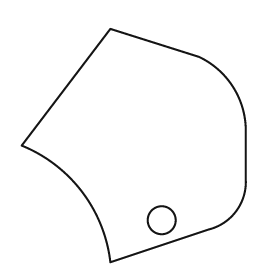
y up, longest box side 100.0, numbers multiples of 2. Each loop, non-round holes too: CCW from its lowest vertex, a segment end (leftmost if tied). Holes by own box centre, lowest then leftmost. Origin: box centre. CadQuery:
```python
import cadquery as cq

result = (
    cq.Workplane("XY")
    .moveTo(-10.0, -50.0)
    .lineTo(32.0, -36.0)
    .threePointArc((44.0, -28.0), (48.0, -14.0))
    .lineTo(48.0, 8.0)
    .threePointArc((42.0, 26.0), (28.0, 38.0))
    .lineTo(-10.0, 50.0)
    .lineTo(-48.0, 0.0)
    .threePointArc((-22.0, -20.0), (-10.0, -50.0))
    .close()
    .moveTo(12.0, -32.0)
    .circle(6.0)
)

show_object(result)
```